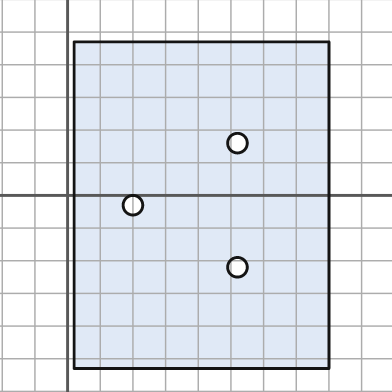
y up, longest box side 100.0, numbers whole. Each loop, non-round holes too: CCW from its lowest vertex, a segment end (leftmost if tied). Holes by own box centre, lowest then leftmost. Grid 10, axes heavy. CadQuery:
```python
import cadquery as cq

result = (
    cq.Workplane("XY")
    .moveTo(2.0, -53.0)
    .lineTo(80.0, -53.0)
    .lineTo(80.0, 47.0)
    .lineTo(2.0, 47.0)
    .close()
    .moveTo(52.0, -22.0)
    .circle(3.0)
    .moveTo(20.0, -3.0)
    .circle(3.0)
    .moveTo(52.0, 16.0)
    .circle(3.0)
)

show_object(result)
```